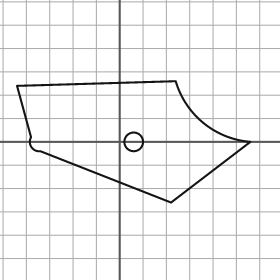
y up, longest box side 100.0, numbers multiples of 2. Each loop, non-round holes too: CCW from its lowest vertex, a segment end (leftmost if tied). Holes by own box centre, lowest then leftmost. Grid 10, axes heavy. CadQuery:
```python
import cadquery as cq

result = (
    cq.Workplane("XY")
    .moveTo(22.0, -26.0)
    .lineTo(56.0, 0.0)
    .threePointArc((36.0, 8.0), (24.0, 26.0))
    .lineTo(-44.0, 24.0)
    .lineTo(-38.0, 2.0)
    .threePointArc((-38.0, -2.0), (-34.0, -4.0))
    .close()
    .moveTo(6.0, 0.0)
    .circle(4.0)
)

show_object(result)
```